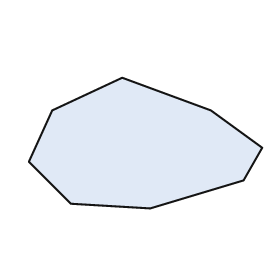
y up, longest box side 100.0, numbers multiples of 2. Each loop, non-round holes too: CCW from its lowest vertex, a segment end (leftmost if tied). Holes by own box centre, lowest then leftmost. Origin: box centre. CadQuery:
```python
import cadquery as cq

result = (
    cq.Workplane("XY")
    .moveTo(2.0, -28.0)
    .lineTo(42.0, -16.0)
    .lineTo(50.0, -2.0)
    .lineTo(28.0, 14.0)
    .lineTo(-10.0, 28.0)
    .lineTo(-40.0, 14.0)
    .lineTo(-50.0, -8.0)
    .lineTo(-32.0, -26.0)
    .close()
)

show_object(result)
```